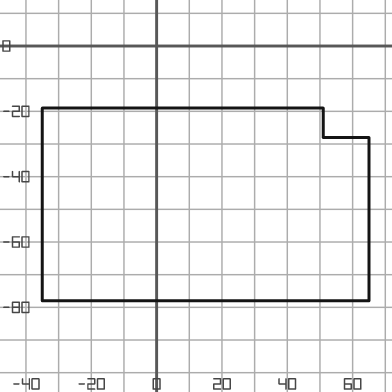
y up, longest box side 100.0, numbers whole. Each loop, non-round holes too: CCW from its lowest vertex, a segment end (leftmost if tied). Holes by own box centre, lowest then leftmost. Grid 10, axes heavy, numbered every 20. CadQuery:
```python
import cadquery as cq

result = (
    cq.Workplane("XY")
    .moveTo(-35.0, -78.0)
    .lineTo(65.0, -78.0)
    .lineTo(65.0, -28.0)
    .lineTo(51.0, -28.0)
    .lineTo(51.0, -19.0)
    .lineTo(-35.0, -19.0)
    .close()
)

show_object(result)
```